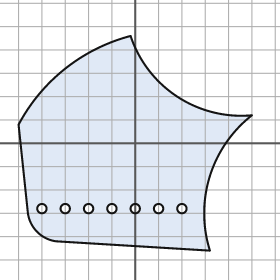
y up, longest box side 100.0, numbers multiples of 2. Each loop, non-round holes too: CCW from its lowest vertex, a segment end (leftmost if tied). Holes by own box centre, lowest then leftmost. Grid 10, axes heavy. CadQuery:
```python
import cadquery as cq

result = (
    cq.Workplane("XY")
    .moveTo(32.0, -46.0)
    .threePointArc((32.0, -14.0), (50.0, 12.0))
    .threePointArc((18.0, 20.0), (-2.0, 46.0))
    .threePointArc((-30.0, 32.0), (-50.0, 8.0))
    .lineTo(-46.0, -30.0)
    .threePointArc((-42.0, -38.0), (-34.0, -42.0))
    .close()
    .moveTo(-40.0, -28.0)
    .circle(2.0)
    .moveTo(-30.0, -28.0)
    .circle(2.0)
    .moveTo(-20.0, -28.0)
    .circle(2.0)
    .moveTo(-10.0, -28.0)
    .circle(2.0)
    .moveTo(0.0, -28.0)
    .circle(2.0)
    .moveTo(10.0, -28.0)
    .circle(2.0)
    .moveTo(20.0, -28.0)
    .circle(2.0)
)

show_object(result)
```